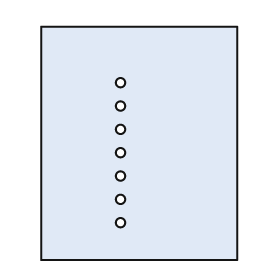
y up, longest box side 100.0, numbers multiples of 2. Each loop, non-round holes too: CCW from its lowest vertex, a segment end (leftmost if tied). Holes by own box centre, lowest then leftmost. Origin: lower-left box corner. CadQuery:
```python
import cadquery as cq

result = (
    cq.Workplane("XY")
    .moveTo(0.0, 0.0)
    .lineTo(84.0, 0.0)
    .lineTo(84.0, 100.0)
    .lineTo(0.0, 100.0)
    .close()
    .moveTo(34.0, 16.0)
    .circle(2.0)
    .moveTo(34.0, 26.0)
    .circle(2.0)
    .moveTo(34.0, 36.0)
    .circle(2.0)
    .moveTo(34.0, 46.0)
    .circle(2.0)
    .moveTo(34.0, 56.0)
    .circle(2.0)
    .moveTo(34.0, 66.0)
    .circle(2.0)
    .moveTo(34.0, 76.0)
    .circle(2.0)
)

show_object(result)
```